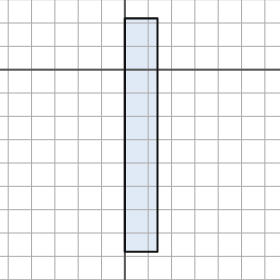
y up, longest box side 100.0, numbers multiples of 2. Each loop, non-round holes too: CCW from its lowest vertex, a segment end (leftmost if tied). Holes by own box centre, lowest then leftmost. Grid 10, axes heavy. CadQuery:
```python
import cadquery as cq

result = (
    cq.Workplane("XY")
    .moveTo(0.0, -78.0)
    .lineTo(14.0, -78.0)
    .lineTo(14.0, 22.0)
    .lineTo(0.0, 22.0)
    .close()
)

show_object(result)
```